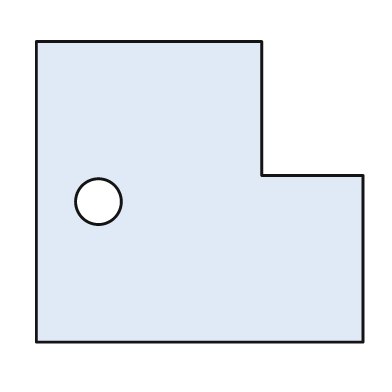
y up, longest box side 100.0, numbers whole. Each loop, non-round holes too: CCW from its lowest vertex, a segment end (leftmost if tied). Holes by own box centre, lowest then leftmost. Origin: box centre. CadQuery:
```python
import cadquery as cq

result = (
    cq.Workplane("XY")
    .moveTo(-50.0, -46.0)
    .lineTo(50.0, -46.0)
    .lineTo(50.0, 5.0)
    .lineTo(19.0, 5.0)
    .lineTo(19.0, 46.0)
    .lineTo(-50.0, 46.0)
    .close()
    .moveTo(-31.0, -3.0)
    .circle(7.0)
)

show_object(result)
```